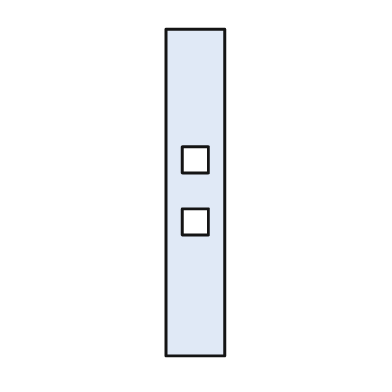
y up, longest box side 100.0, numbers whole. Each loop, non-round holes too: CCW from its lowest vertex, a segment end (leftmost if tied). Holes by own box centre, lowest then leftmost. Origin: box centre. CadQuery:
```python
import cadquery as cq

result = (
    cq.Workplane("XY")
    .moveTo(-9.0, -50.0)
    .lineTo(9.0, -50.0)
    .lineTo(9.0, 50.0)
    .lineTo(-9.0, 50.0)
    .close()
    .moveTo(-4.0, -13.0)
    .lineTo(4.0, -13.0)
    .lineTo(4.0, -5.0)
    .lineTo(-4.0, -5.0)
    .close()
    .moveTo(-4.0, 6.0)
    .lineTo(4.0, 6.0)
    .lineTo(4.0, 14.0)
    .lineTo(-4.0, 14.0)
    .close()
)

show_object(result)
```